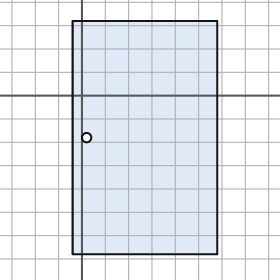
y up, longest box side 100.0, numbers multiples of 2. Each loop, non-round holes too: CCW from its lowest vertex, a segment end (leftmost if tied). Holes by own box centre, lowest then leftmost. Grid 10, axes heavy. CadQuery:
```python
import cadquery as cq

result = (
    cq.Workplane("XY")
    .moveTo(-4.0, -68.0)
    .lineTo(58.0, -68.0)
    .lineTo(58.0, 32.0)
    .lineTo(-4.0, 32.0)
    .close()
    .moveTo(2.0, -18.0)
    .circle(2.0)
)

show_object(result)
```